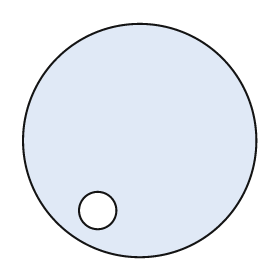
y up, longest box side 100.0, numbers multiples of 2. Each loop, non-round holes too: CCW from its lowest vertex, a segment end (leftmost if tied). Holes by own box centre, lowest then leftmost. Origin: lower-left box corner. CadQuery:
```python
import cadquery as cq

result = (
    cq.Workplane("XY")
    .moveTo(50.0, 50.0)
    .circle(50.0)
    .moveTo(32.0, 20.0)
    .circle(8.0)
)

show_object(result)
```